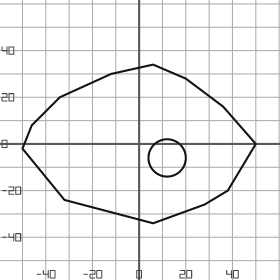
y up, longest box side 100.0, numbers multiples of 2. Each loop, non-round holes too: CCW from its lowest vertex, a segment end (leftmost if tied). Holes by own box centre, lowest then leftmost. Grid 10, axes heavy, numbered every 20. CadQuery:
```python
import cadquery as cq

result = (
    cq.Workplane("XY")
    .moveTo(6.0, -34.0)
    .lineTo(28.0, -26.0)
    .lineTo(38.0, -20.0)
    .lineTo(50.0, 0.0)
    .lineTo(36.0, 16.0)
    .lineTo(20.0, 28.0)
    .lineTo(6.0, 34.0)
    .lineTo(-12.0, 30.0)
    .lineTo(-34.0, 20.0)
    .lineTo(-46.0, 8.0)
    .lineTo(-50.0, -2.0)
    .lineTo(-32.0, -24.0)
    .close()
    .moveTo(12.0, -6.0)
    .circle(8.0)
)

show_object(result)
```